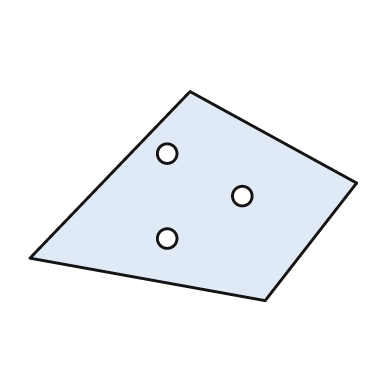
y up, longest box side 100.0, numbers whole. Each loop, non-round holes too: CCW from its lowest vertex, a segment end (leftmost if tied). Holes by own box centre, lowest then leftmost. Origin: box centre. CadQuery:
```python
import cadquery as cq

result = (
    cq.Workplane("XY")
    .moveTo(22.0, -32.0)
    .lineTo(50.0, 4.0)
    .lineTo(-1.0, 32.0)
    .lineTo(-50.0, -19.0)
    .close()
    .moveTo(-8.0, -13.0)
    .circle(3.0)
    .moveTo(15.0, 0.0)
    .circle(3.0)
    .moveTo(-8.0, 13.0)
    .circle(3.0)
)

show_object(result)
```